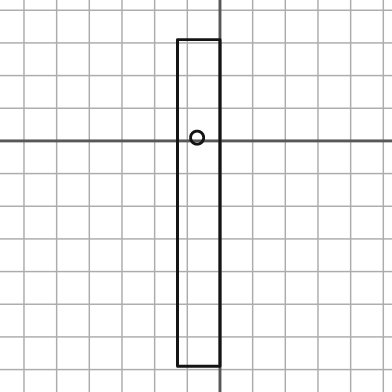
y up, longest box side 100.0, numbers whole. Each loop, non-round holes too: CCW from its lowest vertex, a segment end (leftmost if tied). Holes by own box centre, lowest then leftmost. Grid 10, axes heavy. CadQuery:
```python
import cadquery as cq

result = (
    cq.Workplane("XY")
    .moveTo(-13.0, -69.0)
    .lineTo(0.0, -69.0)
    .lineTo(0.0, 31.0)
    .lineTo(-13.0, 31.0)
    .close()
    .moveTo(-7.0, 1.0)
    .circle(2.0)
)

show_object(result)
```